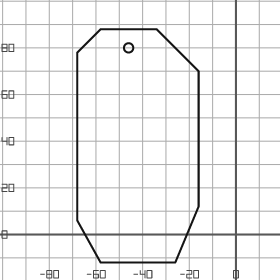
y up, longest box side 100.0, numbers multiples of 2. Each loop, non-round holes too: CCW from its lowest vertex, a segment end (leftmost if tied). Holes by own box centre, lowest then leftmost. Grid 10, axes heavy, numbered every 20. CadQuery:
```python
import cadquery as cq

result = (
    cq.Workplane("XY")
    .moveTo(-58.0, -12.0)
    .lineTo(-26.0, -12.0)
    .lineTo(-16.0, 12.0)
    .lineTo(-16.0, 70.0)
    .lineTo(-34.0, 88.0)
    .lineTo(-58.0, 88.0)
    .lineTo(-68.0, 78.0)
    .lineTo(-68.0, 6.0)
    .close()
    .moveTo(-46.0, 80.0)
    .circle(2.0)
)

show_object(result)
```